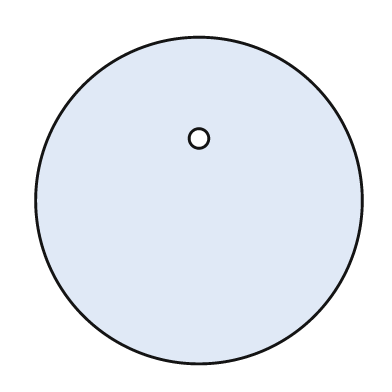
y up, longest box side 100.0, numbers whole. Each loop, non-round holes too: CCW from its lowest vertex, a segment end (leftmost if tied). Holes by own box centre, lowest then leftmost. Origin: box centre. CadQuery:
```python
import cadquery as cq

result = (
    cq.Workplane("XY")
    .moveTo(0.0, 0.0)
    .circle(50.0)
    .moveTo(0.0, 19.0)
    .circle(3.0)
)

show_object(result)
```